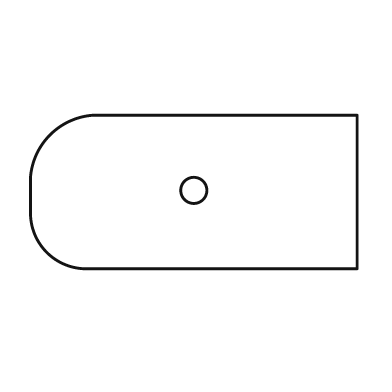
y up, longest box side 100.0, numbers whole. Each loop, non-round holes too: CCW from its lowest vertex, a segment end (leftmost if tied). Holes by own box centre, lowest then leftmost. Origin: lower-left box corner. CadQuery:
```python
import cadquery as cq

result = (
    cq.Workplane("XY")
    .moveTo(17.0, 0.0)
    .lineTo(100.0, 0.0)
    .lineTo(100.0, 47.0)
    .lineTo(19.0, 47.0)
    .threePointArc((6.0, 41.0), (0.0, 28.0))
    .lineTo(0.0, 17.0)
    .threePointArc((5.0, 5.0), (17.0, 0.0))
    .close()
    .moveTo(50.0, 24.0)
    .circle(4.0)
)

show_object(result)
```